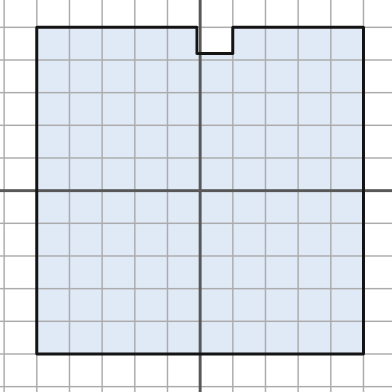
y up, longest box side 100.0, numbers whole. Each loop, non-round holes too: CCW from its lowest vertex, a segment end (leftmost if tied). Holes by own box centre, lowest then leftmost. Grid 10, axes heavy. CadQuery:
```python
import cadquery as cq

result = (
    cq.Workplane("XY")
    .moveTo(-50.0, -50.0)
    .lineTo(50.0, -50.0)
    .lineTo(50.0, 50.0)
    .lineTo(10.0, 50.0)
    .lineTo(10.0, 42.0)
    .lineTo(-1.0, 42.0)
    .lineTo(-1.0, 50.0)
    .lineTo(-50.0, 50.0)
    .close()
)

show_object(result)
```